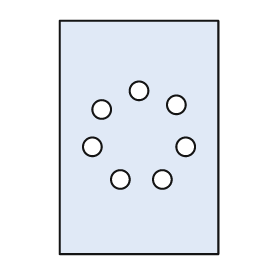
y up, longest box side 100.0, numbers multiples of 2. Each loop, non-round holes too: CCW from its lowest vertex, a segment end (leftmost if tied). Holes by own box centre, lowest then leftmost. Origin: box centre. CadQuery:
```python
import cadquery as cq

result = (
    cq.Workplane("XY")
    .moveTo(-34.0, -50.0)
    .lineTo(34.0, -50.0)
    .lineTo(34.0, 50.0)
    .lineTo(-34.0, 50.0)
    .close()
    .moveTo(-8.0, -18.0)
    .circle(4.0)
    .moveTo(10.0, -18.0)
    .circle(4.0)
    .moveTo(-20.0, -4.0)
    .circle(4.0)
    .moveTo(20.0, -4.0)
    .circle(4.0)
    .moveTo(-16.0, 12.0)
    .circle(4.0)
    .moveTo(16.0, 14.0)
    .circle(4.0)
    .moveTo(0.0, 20.0)
    .circle(4.0)
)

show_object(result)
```